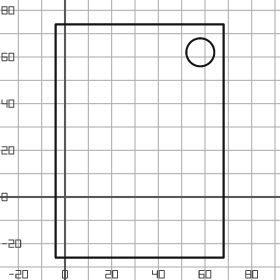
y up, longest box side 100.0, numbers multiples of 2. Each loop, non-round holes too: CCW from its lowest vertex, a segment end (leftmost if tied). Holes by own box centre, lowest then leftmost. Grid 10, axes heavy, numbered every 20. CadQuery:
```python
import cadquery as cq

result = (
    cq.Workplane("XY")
    .moveTo(-4.0, -26.0)
    .lineTo(68.0, -26.0)
    .lineTo(68.0, 74.0)
    .lineTo(-4.0, 74.0)
    .close()
    .moveTo(58.0, 62.0)
    .circle(6.0)
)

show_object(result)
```